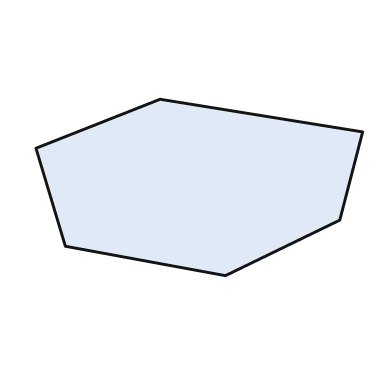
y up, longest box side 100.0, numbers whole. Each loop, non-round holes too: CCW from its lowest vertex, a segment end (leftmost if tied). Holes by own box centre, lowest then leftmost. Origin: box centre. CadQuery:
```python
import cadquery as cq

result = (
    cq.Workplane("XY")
    .moveTo(8.0, -27.0)
    .lineTo(43.0, -10.0)
    .lineTo(50.0, 17.0)
    .lineTo(-12.0, 27.0)
    .lineTo(-50.0, 12.0)
    .lineTo(-41.0, -18.0)
    .close()
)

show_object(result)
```